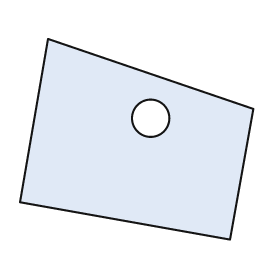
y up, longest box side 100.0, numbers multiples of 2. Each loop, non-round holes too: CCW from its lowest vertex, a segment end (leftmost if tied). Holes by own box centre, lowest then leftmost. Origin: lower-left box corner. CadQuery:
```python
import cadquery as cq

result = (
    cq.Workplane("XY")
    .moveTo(90.0, 0.0)
    .lineTo(100.0, 56.0)
    .lineTo(12.0, 86.0)
    .lineTo(0.0, 16.0)
    .close()
    .moveTo(56.0, 52.0)
    .circle(8.0)
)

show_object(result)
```